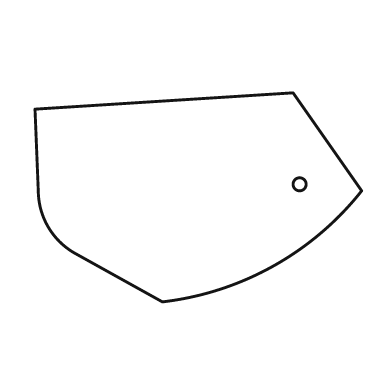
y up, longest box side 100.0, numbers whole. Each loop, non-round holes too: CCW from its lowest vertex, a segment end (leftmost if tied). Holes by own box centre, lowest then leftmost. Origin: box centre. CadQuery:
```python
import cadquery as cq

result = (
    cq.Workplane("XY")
    .moveTo(-11.0, -32.0)
    .threePointArc((23.0, -21.0), (50.0, 2.0))
    .lineTo(29.0, 32.0)
    .lineTo(-50.0, 27.0)
    .lineTo(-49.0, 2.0)
    .threePointArc((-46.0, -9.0), (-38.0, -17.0))
    .close()
    .moveTo(31.0, 4.0)
    .circle(2.0)
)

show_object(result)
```